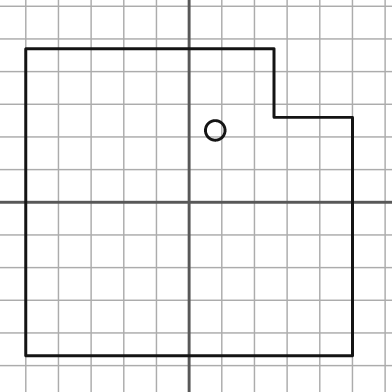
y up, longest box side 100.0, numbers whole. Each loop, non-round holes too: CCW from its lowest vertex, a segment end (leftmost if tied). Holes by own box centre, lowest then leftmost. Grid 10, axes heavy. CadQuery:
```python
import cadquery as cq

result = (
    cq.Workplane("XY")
    .moveTo(-50.0, -47.0)
    .lineTo(50.0, -47.0)
    .lineTo(50.0, 26.0)
    .lineTo(26.0, 26.0)
    .lineTo(26.0, 47.0)
    .lineTo(-50.0, 47.0)
    .close()
    .moveTo(8.0, 22.0)
    .circle(3.0)
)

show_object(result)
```